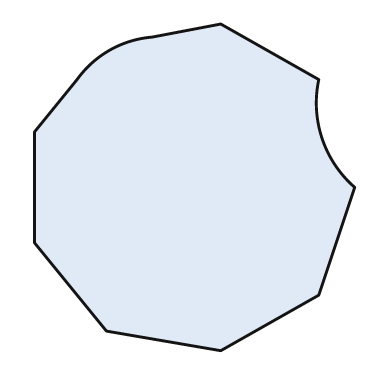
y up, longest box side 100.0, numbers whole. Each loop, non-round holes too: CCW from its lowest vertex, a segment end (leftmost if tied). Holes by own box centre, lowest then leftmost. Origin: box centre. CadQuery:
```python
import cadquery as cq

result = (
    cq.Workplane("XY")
    .moveTo(8.0, -50.0)
    .lineTo(38.0, -33.0)
    .lineTo(49.0, 0.0)
    .threePointArc((39.0, 15.0), (38.0, 33.0))
    .lineTo(8.0, 50.0)
    .lineTo(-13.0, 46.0)
    .threePointArc((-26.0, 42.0), (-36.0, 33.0))
    .lineTo(-49.0, 17.0)
    .lineTo(-49.0, -17.0)
    .lineTo(-27.0, -44.0)
    .close()
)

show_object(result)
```